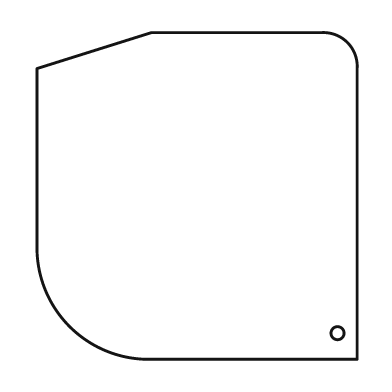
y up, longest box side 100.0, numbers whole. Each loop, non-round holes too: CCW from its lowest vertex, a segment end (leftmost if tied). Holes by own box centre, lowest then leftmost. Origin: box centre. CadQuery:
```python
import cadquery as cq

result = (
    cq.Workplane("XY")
    .moveTo(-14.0, -50.0)
    .lineTo(49.0, -50.0)
    .lineTo(49.0, 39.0)
    .threePointArc((46.0, 47.0), (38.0, 50.0))
    .lineTo(-14.0, 50.0)
    .lineTo(-49.0, 39.0)
    .lineTo(-49.0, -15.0)
    .threePointArc((-39.0, -40.0), (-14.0, -50.0))
    .close()
    .moveTo(43.0, -42.0)
    .circle(2.0)
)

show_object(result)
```